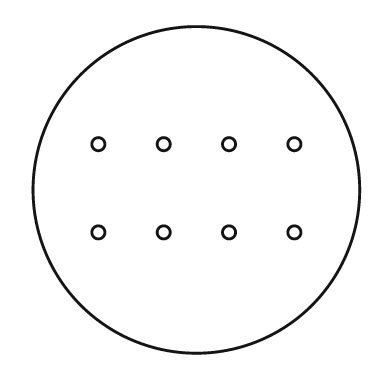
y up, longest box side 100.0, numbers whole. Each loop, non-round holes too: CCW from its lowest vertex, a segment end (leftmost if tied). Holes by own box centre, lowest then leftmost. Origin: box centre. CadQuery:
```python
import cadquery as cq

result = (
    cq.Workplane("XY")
    .moveTo(0.0, 0.0)
    .circle(50.0)
    .moveTo(-30.0, -13.0)
    .circle(2.0)
    .moveTo(-10.0, -13.0)
    .circle(2.0)
    .moveTo(10.0, -13.0)
    .circle(2.0)
    .moveTo(30.0, -13.0)
    .circle(2.0)
    .moveTo(-30.0, 14.0)
    .circle(2.0)
    .moveTo(-10.0, 14.0)
    .circle(2.0)
    .moveTo(10.0, 14.0)
    .circle(2.0)
    .moveTo(30.0, 14.0)
    .circle(2.0)
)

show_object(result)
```